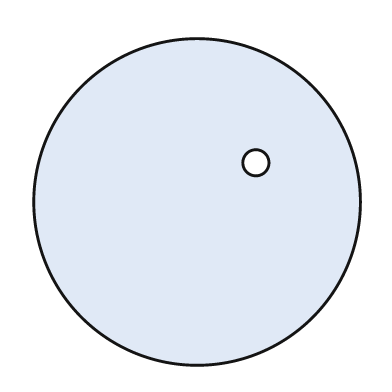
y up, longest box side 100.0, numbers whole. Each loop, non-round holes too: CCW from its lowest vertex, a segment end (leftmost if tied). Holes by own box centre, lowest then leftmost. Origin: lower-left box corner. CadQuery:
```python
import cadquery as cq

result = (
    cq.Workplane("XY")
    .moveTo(50.0, 50.0)
    .circle(50.0)
    .moveTo(68.0, 62.0)
    .circle(4.0)
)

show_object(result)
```